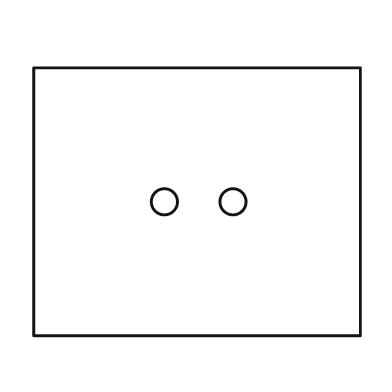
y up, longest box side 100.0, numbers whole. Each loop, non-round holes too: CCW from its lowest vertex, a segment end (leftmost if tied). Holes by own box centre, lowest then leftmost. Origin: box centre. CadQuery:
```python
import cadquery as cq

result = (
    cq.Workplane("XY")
    .moveTo(-50.0, -41.0)
    .lineTo(50.0, -41.0)
    .lineTo(50.0, 41.0)
    .lineTo(-50.0, 41.0)
    .close()
    .moveTo(-10.0, 0.0)
    .circle(4.0)
    .moveTo(11.0, 0.0)
    .circle(4.0)
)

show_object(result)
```